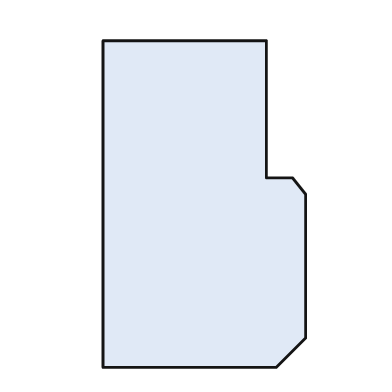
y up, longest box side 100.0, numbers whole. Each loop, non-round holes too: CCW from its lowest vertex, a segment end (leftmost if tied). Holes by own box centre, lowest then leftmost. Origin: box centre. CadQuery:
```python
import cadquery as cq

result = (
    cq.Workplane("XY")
    .moveTo(-31.0, -50.0)
    .lineTo(22.0, -50.0)
    .lineTo(31.0, -41.0)
    .lineTo(31.0, 3.0)
    .lineTo(27.0, 8.0)
    .lineTo(19.0, 8.0)
    .lineTo(19.0, 50.0)
    .lineTo(-31.0, 50.0)
    .close()
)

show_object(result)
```